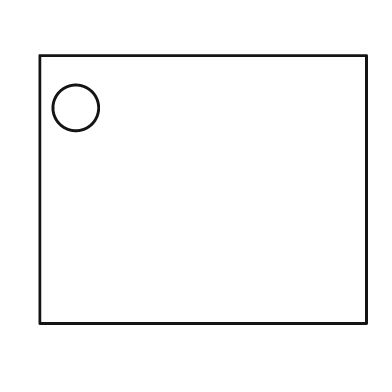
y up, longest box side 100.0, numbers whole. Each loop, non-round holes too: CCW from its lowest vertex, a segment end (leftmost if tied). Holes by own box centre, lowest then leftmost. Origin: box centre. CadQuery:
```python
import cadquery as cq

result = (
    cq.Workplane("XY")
    .moveTo(-50.0, -41.0)
    .lineTo(50.0, -41.0)
    .lineTo(50.0, 41.0)
    .lineTo(-50.0, 41.0)
    .close()
    .moveTo(-39.0, 25.0)
    .circle(7.0)
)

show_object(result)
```